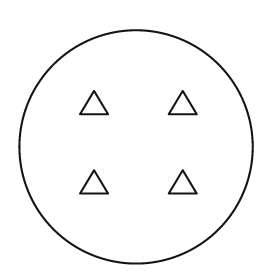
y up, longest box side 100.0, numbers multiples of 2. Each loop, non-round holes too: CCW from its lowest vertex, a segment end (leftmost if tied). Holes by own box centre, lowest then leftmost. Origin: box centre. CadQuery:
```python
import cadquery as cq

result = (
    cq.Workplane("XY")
    .moveTo(0.0, 0.0)
    .circle(50.0)
    .moveTo(-24.0, -20.0)
    .lineTo(-12.0, -20.0)
    .lineTo(-18.0, -10.0)
    .close()
    .moveTo(14.0, -20.0)
    .lineTo(26.0, -20.0)
    .lineTo(20.0, -10.0)
    .close()
    .moveTo(-24.0, 14.0)
    .lineTo(-12.0, 14.0)
    .lineTo(-18.0, 24.0)
    .close()
    .moveTo(14.0, 14.0)
    .lineTo(26.0, 14.0)
    .lineTo(20.0, 24.0)
    .close()
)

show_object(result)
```